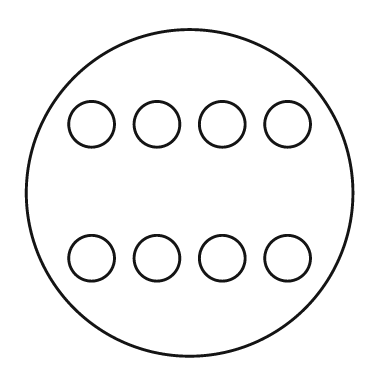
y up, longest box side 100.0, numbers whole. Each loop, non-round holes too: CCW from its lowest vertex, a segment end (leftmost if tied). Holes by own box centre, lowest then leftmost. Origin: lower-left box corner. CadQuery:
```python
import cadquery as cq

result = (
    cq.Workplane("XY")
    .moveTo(50.0, 50.0)
    .circle(50.0)
    .moveTo(20.0, 30.0)
    .circle(7.0)
    .moveTo(40.0, 30.0)
    .circle(7.0)
    .moveTo(60.0, 30.0)
    .circle(7.0)
    .moveTo(80.0, 30.0)
    .circle(7.0)
    .moveTo(20.0, 71.0)
    .circle(7.0)
    .moveTo(40.0, 71.0)
    .circle(7.0)
    .moveTo(60.0, 71.0)
    .circle(7.0)
    .moveTo(80.0, 71.0)
    .circle(7.0)
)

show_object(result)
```